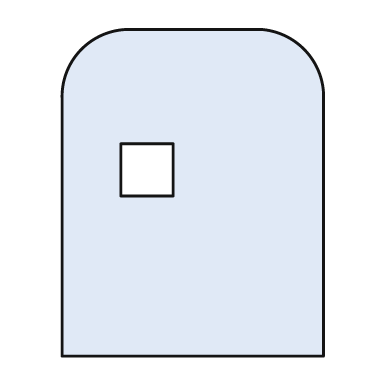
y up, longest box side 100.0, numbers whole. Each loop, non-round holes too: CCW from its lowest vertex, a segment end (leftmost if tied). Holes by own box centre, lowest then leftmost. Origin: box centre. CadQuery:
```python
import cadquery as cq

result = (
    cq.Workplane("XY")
    .moveTo(-40.0, -50.0)
    .lineTo(40.0, -50.0)
    .lineTo(40.0, 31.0)
    .threePointArc((34.0, 44.0), (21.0, 50.0))
    .lineTo(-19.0, 50.0)
    .threePointArc((-34.0, 44.0), (-40.0, 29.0))
    .close()
    .moveTo(-22.0, -1.0)
    .lineTo(-6.0, -1.0)
    .lineTo(-6.0, 15.0)
    .lineTo(-22.0, 15.0)
    .close()
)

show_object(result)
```